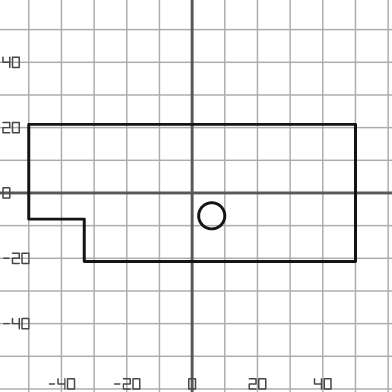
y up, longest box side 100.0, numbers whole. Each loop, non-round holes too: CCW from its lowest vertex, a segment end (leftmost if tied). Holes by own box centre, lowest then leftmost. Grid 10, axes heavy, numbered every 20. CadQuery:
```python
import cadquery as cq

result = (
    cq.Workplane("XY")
    .moveTo(-33.0, -21.0)
    .lineTo(50.0, -21.0)
    .lineTo(50.0, 21.0)
    .lineTo(-50.0, 21.0)
    .lineTo(-50.0, -8.0)
    .lineTo(-33.0, -8.0)
    .close()
    .moveTo(6.0, -7.0)
    .circle(4.0)
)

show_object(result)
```